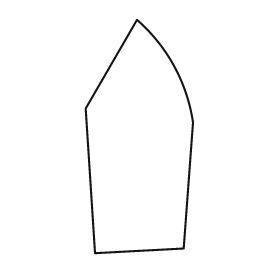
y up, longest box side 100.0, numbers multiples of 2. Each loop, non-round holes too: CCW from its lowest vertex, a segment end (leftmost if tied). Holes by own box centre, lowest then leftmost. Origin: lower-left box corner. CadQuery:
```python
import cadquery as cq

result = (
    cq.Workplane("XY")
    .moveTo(4.0, 0.0)
    .lineTo(42.0, 2.0)
    .lineTo(46.0, 56.0)
    .threePointArc((38.0, 80.0), (22.0, 100.0))
    .lineTo(0.0, 62.0)
    .close()
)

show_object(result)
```